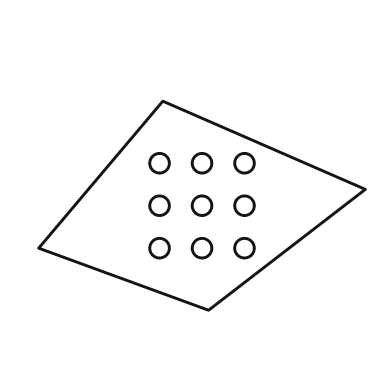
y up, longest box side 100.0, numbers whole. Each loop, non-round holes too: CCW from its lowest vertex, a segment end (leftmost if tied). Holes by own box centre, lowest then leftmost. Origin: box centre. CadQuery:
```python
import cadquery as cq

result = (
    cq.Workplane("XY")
    .moveTo(2.0, -32.0)
    .lineTo(50.0, 5.0)
    .lineTo(-12.0, 32.0)
    .lineTo(-50.0, -13.0)
    .close()
    .moveTo(-13.0, -13.0)
    .circle(3.0)
    .moveTo(0.0, -13.0)
    .circle(3.0)
    .moveTo(13.0, -13.0)
    .circle(3.0)
    .moveTo(-13.0, 0.0)
    .circle(3.0)
    .moveTo(0.0, 0.0)
    .circle(3.0)
    .moveTo(13.0, 0.0)
    .circle(3.0)
    .moveTo(-13.0, 13.0)
    .circle(3.0)
    .moveTo(0.0, 13.0)
    .circle(3.0)
    .moveTo(13.0, 13.0)
    .circle(3.0)
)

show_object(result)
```